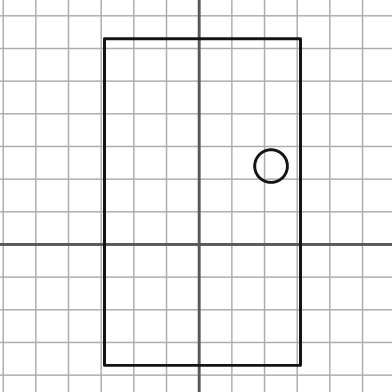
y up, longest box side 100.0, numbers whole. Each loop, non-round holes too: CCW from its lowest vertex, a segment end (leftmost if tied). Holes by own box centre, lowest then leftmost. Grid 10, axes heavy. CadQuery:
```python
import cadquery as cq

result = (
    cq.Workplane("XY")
    .moveTo(-29.0, -37.0)
    .lineTo(31.0, -37.0)
    .lineTo(31.0, 63.0)
    .lineTo(-29.0, 63.0)
    .close()
    .moveTo(22.0, 24.0)
    .circle(5.0)
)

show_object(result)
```